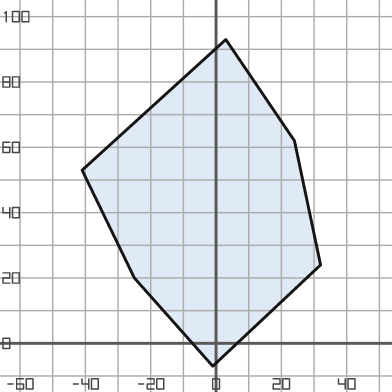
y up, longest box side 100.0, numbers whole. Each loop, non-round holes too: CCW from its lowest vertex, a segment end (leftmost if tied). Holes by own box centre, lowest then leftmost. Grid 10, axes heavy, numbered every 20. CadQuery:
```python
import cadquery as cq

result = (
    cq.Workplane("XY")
    .moveTo(-1.0, -7.0)
    .lineTo(32.0, 24.0)
    .lineTo(24.0, 62.0)
    .lineTo(3.0, 93.0)
    .lineTo(-41.0, 53.0)
    .lineTo(-25.0, 20.0)
    .close()
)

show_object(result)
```